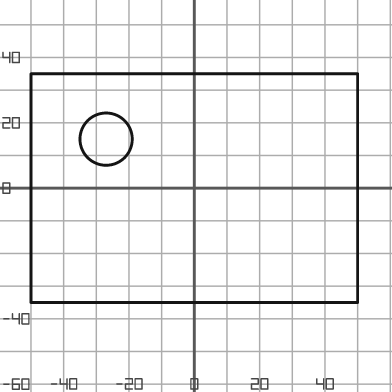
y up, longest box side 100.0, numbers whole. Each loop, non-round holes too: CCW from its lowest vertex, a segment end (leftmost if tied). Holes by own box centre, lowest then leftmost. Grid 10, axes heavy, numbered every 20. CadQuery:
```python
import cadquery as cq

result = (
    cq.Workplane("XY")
    .moveTo(-50.0, -35.0)
    .lineTo(50.0, -35.0)
    .lineTo(50.0, 35.0)
    .lineTo(-50.0, 35.0)
    .close()
    .moveTo(-27.0, 15.0)
    .circle(8.0)
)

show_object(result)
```